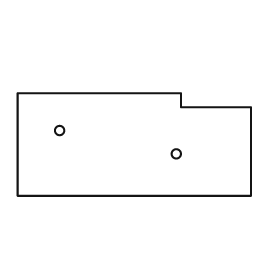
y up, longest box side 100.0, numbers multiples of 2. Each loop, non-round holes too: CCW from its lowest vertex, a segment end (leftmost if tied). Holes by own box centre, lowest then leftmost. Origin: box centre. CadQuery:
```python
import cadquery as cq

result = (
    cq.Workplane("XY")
    .moveTo(-50.0, -22.0)
    .lineTo(50.0, -22.0)
    .lineTo(50.0, 16.0)
    .lineTo(20.0, 16.0)
    .lineTo(20.0, 22.0)
    .lineTo(-50.0, 22.0)
    .close()
    .moveTo(18.0, -4.0)
    .circle(2.0)
    .moveTo(-32.0, 6.0)
    .circle(2.0)
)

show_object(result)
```